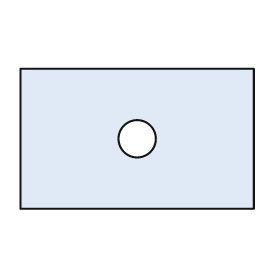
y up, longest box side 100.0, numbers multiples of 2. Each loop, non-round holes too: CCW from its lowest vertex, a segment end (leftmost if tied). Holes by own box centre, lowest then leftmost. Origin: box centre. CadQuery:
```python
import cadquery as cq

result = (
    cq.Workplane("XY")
    .moveTo(-50.0, -30.0)
    .lineTo(50.0, -30.0)
    .lineTo(50.0, 30.0)
    .lineTo(-50.0, 30.0)
    .close()
    .moveTo(0.0, 0.0)
    .circle(8.0)
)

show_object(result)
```